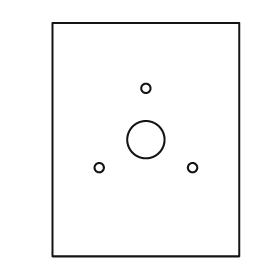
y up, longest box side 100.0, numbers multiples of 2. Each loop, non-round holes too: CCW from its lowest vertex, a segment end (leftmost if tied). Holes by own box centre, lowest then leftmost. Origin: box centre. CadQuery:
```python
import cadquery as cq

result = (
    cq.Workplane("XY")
    .moveTo(-40.0, -50.0)
    .lineTo(40.0, -50.0)
    .lineTo(40.0, 50.0)
    .lineTo(-40.0, 50.0)
    .close()
    .moveTo(-20.0, -12.0)
    .circle(2.0)
    .moveTo(20.0, -12.0)
    .circle(2.0)
    .moveTo(0.0, 0.0)
    .circle(8.0)
    .moveTo(0.0, 22.0)
    .circle(2.0)
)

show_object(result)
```